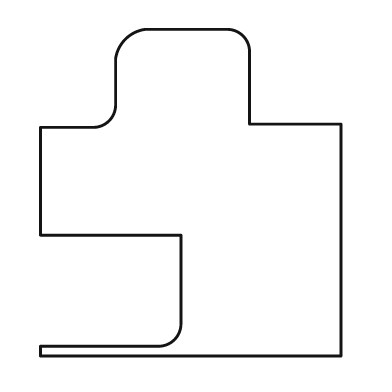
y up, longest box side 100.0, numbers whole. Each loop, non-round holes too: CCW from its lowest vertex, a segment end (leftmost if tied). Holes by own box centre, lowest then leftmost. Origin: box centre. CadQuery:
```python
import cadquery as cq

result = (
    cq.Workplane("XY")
    .moveTo(-46.0, -50.0)
    .lineTo(46.0, -50.0)
    .lineTo(46.0, 21.0)
    .lineTo(18.0, 21.0)
    .lineTo(18.0, 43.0)
    .threePointArc((16.0, 48.0), (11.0, 50.0))
    .lineTo(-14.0, 50.0)
    .threePointArc((-20.0, 47.0), (-23.0, 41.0))
    .lineTo(-23.0, 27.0)
    .threePointArc((-25.0, 22.0), (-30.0, 20.0))
    .lineTo(-46.0, 20.0)
    .lineTo(-46.0, -13.0)
    .lineTo(-3.0, -13.0)
    .lineTo(-3.0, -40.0)
    .threePointArc((-5.0, -45.0), (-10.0, -47.0))
    .lineTo(-46.0, -47.0)
    .close()
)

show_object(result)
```